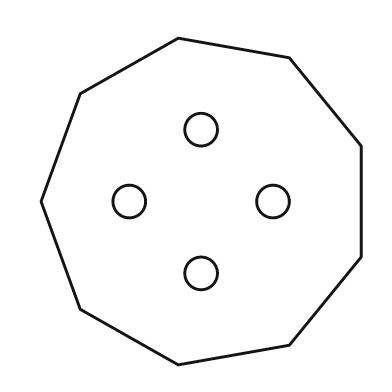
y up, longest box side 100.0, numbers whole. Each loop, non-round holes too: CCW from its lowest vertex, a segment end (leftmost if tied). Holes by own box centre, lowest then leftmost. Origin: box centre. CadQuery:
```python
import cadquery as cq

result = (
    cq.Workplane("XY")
    .moveTo(-7.0, -50.0)
    .lineTo(27.0, -44.0)
    .lineTo(49.0, -17.0)
    .lineTo(49.0, 17.0)
    .lineTo(27.0, 44.0)
    .lineTo(-7.0, 50.0)
    .lineTo(-37.0, 33.0)
    .lineTo(-49.0, 0.0)
    .lineTo(-37.0, -33.0)
    .close()
    .moveTo(0.0, -22.0)
    .circle(5.0)
    .moveTo(-22.0, 0.0)
    .circle(5.0)
    .moveTo(22.0, 0.0)
    .circle(5.0)
    .moveTo(0.0, 22.0)
    .circle(5.0)
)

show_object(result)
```